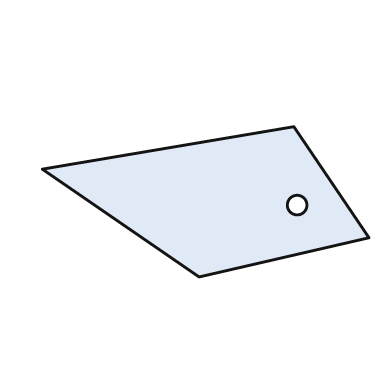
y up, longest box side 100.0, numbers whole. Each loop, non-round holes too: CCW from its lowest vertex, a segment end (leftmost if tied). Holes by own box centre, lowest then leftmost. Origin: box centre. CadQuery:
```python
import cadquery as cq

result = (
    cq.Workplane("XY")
    .moveTo(-2.0, -23.0)
    .lineTo(50.0, -11.0)
    .lineTo(27.0, 23.0)
    .lineTo(-50.0, 10.0)
    .close()
    .moveTo(28.0, -1.0)
    .circle(3.0)
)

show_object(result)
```